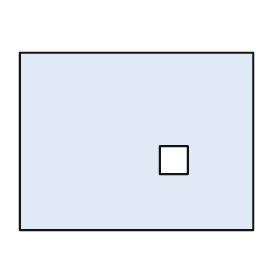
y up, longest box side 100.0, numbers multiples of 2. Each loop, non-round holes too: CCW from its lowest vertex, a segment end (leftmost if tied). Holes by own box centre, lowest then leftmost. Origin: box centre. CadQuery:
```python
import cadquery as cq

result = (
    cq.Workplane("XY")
    .moveTo(-50.0, -38.0)
    .lineTo(50.0, -38.0)
    .lineTo(50.0, 38.0)
    .lineTo(-50.0, 38.0)
    .close()
    .moveTo(10.0, -14.0)
    .lineTo(22.0, -14.0)
    .lineTo(22.0, -2.0)
    .lineTo(10.0, -2.0)
    .close()
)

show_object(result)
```